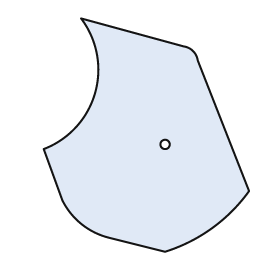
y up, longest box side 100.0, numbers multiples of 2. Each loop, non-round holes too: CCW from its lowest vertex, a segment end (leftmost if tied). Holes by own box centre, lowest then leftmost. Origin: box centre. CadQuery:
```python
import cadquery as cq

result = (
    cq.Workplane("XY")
    .moveTo(8.0, -50.0)
    .threePointArc((28.0, -40.0), (44.0, -24.0))
    .lineTo(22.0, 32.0)
    .threePointArc((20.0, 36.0), (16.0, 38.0))
    .lineTo(-28.0, 50.0)
    .threePointArc((-22.0, 18.0), (-44.0, -6.0))
    .lineTo(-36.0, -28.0)
    .threePointArc((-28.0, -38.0), (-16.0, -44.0))
    .close()
    .moveTo(8.0, -4.0)
    .circle(2.0)
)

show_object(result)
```